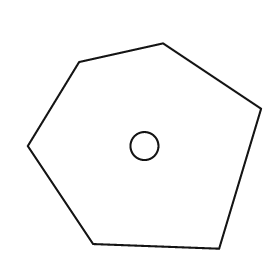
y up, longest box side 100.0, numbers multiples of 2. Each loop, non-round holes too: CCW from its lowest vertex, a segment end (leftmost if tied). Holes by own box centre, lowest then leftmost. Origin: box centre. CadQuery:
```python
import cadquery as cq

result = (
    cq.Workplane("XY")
    .moveTo(32.0, -44.0)
    .lineTo(50.0, 16.0)
    .lineTo(8.0, 44.0)
    .lineTo(-28.0, 36.0)
    .lineTo(-50.0, 0.0)
    .lineTo(-22.0, -42.0)
    .close()
    .moveTo(0.0, 0.0)
    .circle(6.0)
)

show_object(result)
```